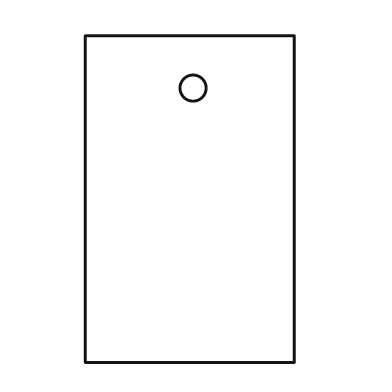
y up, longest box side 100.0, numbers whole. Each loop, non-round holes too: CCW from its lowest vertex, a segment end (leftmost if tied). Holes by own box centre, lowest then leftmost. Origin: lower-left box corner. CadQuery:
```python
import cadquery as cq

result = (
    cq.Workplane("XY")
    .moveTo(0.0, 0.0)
    .lineTo(64.0, 0.0)
    .lineTo(64.0, 100.0)
    .lineTo(0.0, 100.0)
    .close()
    .moveTo(33.0, 84.0)
    .circle(4.0)
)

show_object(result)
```